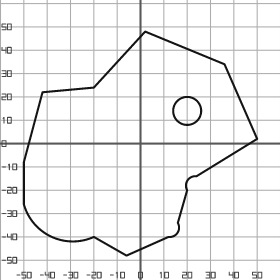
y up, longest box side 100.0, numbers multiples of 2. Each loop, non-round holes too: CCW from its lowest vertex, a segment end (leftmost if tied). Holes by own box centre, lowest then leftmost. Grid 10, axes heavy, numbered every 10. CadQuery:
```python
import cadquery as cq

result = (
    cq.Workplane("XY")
    .moveTo(-6.0, -48.0)
    .lineTo(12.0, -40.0)
    .threePointArc((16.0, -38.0), (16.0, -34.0))
    .lineTo(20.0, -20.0)
    .threePointArc((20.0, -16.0), (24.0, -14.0))
    .lineTo(50.0, 2.0)
    .lineTo(36.0, 34.0)
    .lineTo(2.0, 48.0)
    .lineTo(-20.0, 24.0)
    .lineTo(-42.0, 22.0)
    .lineTo(-50.0, -8.0)
    .lineTo(-50.0, -26.0)
    .threePointArc((-38.0, -40.0), (-20.0, -40.0))
    .close()
    .moveTo(20.0, 14.0)
    .circle(6.0)
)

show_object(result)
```